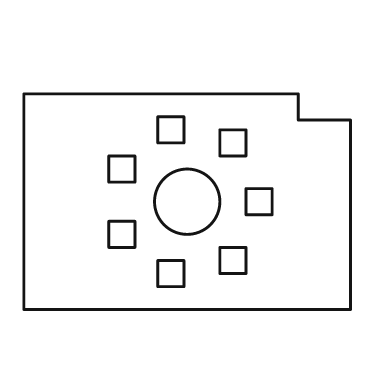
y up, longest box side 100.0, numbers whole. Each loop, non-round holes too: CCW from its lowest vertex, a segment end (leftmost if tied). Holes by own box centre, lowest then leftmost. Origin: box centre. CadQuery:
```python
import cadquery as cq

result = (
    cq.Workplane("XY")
    .moveTo(-50.0, -33.0)
    .lineTo(50.0, -33.0)
    .lineTo(50.0, 25.0)
    .lineTo(34.0, 25.0)
    .lineTo(34.0, 33.0)
    .lineTo(-50.0, 33.0)
    .close()
    .moveTo(-9.0, -26.0)
    .lineTo(-1.0, -26.0)
    .lineTo(-1.0, -18.0)
    .lineTo(-9.0, -18.0)
    .close()
    .moveTo(10.0, -22.0)
    .lineTo(18.0, -22.0)
    .lineTo(18.0, -14.0)
    .lineTo(10.0, -14.0)
    .close()
    .moveTo(-24.0, -14.0)
    .lineTo(-16.0, -14.0)
    .lineTo(-16.0, -6.0)
    .lineTo(-24.0, -6.0)
    .close()
    .moveTo(0.0, 0.0)
    .circle(10.0)
    .moveTo(18.0, -4.0)
    .lineTo(26.0, -4.0)
    .lineTo(26.0, 4.0)
    .lineTo(18.0, 4.0)
    .close()
    .moveTo(-24.0, 6.0)
    .lineTo(-16.0, 6.0)
    .lineTo(-16.0, 14.0)
    .lineTo(-24.0, 14.0)
    .close()
    .moveTo(10.0, 14.0)
    .lineTo(18.0, 14.0)
    .lineTo(18.0, 22.0)
    .lineTo(10.0, 22.0)
    .close()
    .moveTo(-9.0, 18.0)
    .lineTo(-1.0, 18.0)
    .lineTo(-1.0, 26.0)
    .lineTo(-9.0, 26.0)
    .close()
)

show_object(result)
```